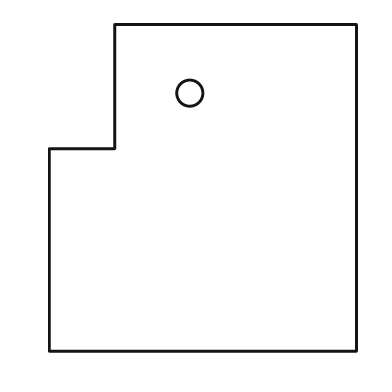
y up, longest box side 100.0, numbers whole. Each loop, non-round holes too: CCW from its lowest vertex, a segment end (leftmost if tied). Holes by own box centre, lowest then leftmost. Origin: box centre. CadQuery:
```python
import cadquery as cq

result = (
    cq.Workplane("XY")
    .moveTo(-47.0, -50.0)
    .lineTo(47.0, -50.0)
    .lineTo(47.0, 50.0)
    .lineTo(-27.0, 50.0)
    .lineTo(-27.0, 12.0)
    .lineTo(-47.0, 12.0)
    .close()
    .moveTo(-4.0, 29.0)
    .circle(4.0)
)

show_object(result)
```